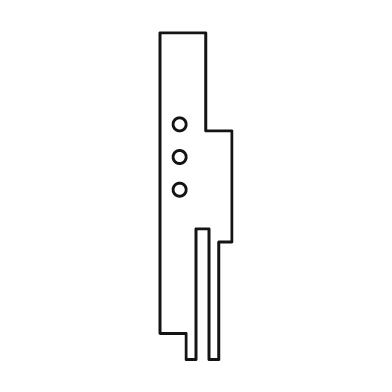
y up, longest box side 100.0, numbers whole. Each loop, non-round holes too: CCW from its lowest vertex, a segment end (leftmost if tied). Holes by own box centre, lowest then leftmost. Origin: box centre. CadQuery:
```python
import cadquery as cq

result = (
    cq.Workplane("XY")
    .moveTo(-3.0, -50.0)
    .lineTo(0.0, -50.0)
    .lineTo(0.0, -10.0)
    .lineTo(4.0, -10.0)
    .lineTo(4.0, -50.0)
    .lineTo(7.0, -50.0)
    .lineTo(7.0, -14.0)
    .lineTo(11.0, -14.0)
    .lineTo(11.0, 20.0)
    .lineTo(3.0, 20.0)
    .lineTo(3.0, 50.0)
    .lineTo(-11.0, 50.0)
    .lineTo(-11.0, -42.0)
    .lineTo(-3.0, -42.0)
    .close()
    .moveTo(-5.0, 2.0)
    .circle(2.0)
    .moveTo(-5.0, 12.0)
    .circle(2.0)
    .moveTo(-5.0, 22.0)
    .circle(2.0)
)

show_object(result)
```